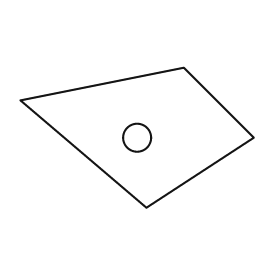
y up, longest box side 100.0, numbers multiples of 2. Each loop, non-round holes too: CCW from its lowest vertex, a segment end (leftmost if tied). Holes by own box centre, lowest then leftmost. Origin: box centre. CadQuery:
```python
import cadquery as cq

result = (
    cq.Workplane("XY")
    .moveTo(4.0, -30.0)
    .lineTo(50.0, 0.0)
    .lineTo(20.0, 30.0)
    .lineTo(-50.0, 16.0)
    .close()
    .moveTo(0.0, 0.0)
    .circle(6.0)
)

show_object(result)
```